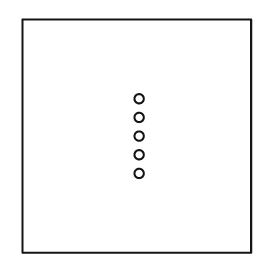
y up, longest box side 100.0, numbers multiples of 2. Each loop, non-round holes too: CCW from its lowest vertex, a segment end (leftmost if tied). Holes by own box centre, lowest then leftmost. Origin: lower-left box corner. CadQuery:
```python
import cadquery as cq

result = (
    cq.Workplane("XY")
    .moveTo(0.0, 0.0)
    .lineTo(98.0, 0.0)
    .lineTo(98.0, 100.0)
    .lineTo(0.0, 100.0)
    .close()
    .moveTo(50.0, 34.0)
    .circle(2.0)
    .moveTo(50.0, 42.0)
    .circle(2.0)
    .moveTo(50.0, 50.0)
    .circle(2.0)
    .moveTo(50.0, 58.0)
    .circle(2.0)
    .moveTo(50.0, 66.0)
    .circle(2.0)
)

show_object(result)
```